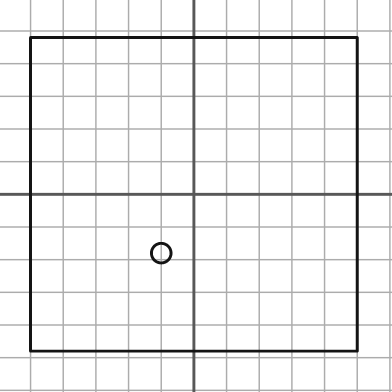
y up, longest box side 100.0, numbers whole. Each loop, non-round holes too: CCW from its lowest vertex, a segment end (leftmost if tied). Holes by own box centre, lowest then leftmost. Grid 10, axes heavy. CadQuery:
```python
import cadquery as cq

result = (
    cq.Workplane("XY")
    .moveTo(-50.0, -48.0)
    .lineTo(50.0, -48.0)
    .lineTo(50.0, 48.0)
    .lineTo(-50.0, 48.0)
    .close()
    .moveTo(-10.0, -18.0)
    .circle(3.0)
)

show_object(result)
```